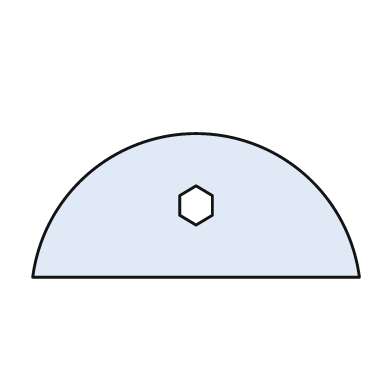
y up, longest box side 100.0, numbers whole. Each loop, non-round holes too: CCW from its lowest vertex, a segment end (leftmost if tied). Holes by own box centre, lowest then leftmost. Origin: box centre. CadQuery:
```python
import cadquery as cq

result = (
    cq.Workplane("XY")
    .moveTo(-50.0, -22.0)
    .lineTo(50.0, -22.0)
    .threePointArc((0.0, 22.0), (-50.0, -22.0))
    .close()
    .moveTo(0.0, -6.0)
    .lineTo(5.0, -3.0)
    .lineTo(5.0, 3.0)
    .lineTo(0.0, 6.0)
    .lineTo(-5.0, 3.0)
    .lineTo(-5.0, -3.0)
    .close()
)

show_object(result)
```